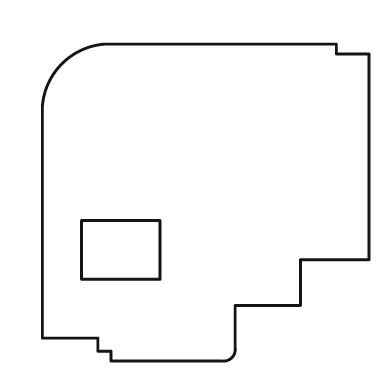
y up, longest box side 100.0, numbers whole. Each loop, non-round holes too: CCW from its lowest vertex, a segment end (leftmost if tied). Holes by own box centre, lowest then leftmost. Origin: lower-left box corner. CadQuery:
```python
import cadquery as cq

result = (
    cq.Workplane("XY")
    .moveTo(21.0, 0.0)
    .lineTo(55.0, 0.0)
    .threePointArc((58.0, 1.0), (59.0, 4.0))
    .lineTo(59.0, 17.0)
    .lineTo(79.0, 17.0)
    .lineTo(79.0, 31.0)
    .lineTo(100.0, 31.0)
    .lineTo(100.0, 94.0)
    .lineTo(90.0, 94.0)
    .lineTo(90.0, 97.0)
    .lineTo(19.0, 97.0)
    .threePointArc((6.0, 91.0), (0.0, 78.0))
    .lineTo(0.0, 7.0)
    .lineTo(17.0, 7.0)
    .lineTo(17.0, 3.0)
    .lineTo(21.0, 3.0)
    .close()
    .moveTo(12.0, 25.0)
    .lineTo(36.0, 25.0)
    .lineTo(36.0, 43.0)
    .lineTo(12.0, 43.0)
    .close()
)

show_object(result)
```